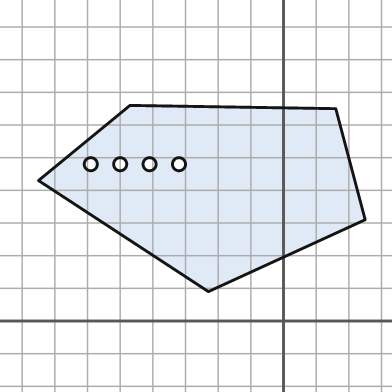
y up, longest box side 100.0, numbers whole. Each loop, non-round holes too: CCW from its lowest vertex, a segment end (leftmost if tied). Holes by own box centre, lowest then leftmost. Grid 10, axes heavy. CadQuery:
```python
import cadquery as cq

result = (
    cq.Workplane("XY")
    .moveTo(-23.0, 9.0)
    .lineTo(25.0, 31.0)
    .lineTo(16.0, 65.0)
    .lineTo(-47.0, 66.0)
    .lineTo(-75.0, 43.0)
    .close()
    .moveTo(-59.0, 48.0)
    .circle(2.0)
    .moveTo(-50.0, 48.0)
    .circle(2.0)
    .moveTo(-41.0, 48.0)
    .circle(2.0)
    .moveTo(-32.0, 48.0)
    .circle(2.0)
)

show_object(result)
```